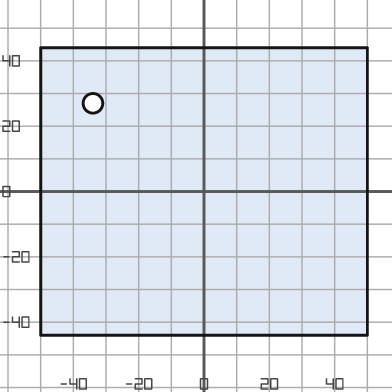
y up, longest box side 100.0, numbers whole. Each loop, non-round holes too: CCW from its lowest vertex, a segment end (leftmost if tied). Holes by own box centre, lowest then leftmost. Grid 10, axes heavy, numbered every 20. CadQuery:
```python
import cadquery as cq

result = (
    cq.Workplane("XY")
    .moveTo(-50.0, -44.0)
    .lineTo(50.0, -44.0)
    .lineTo(50.0, 44.0)
    .lineTo(-50.0, 44.0)
    .close()
    .moveTo(-34.0, 27.0)
    .circle(3.0)
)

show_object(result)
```